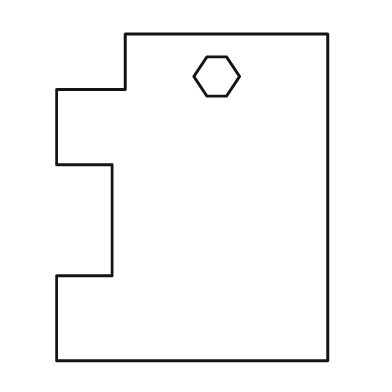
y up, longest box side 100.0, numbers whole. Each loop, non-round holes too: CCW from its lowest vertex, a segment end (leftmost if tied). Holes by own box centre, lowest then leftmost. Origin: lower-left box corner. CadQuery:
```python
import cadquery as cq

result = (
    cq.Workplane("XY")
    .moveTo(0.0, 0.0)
    .lineTo(83.0, 0.0)
    .lineTo(83.0, 100.0)
    .lineTo(21.0, 100.0)
    .lineTo(21.0, 83.0)
    .lineTo(0.0, 83.0)
    .lineTo(0.0, 60.0)
    .lineTo(17.0, 60.0)
    .lineTo(17.0, 26.0)
    .lineTo(0.0, 26.0)
    .close()
    .moveTo(46.0, 81.0)
    .lineTo(52.0, 81.0)
    .lineTo(56.0, 87.0)
    .lineTo(52.0, 93.0)
    .lineTo(46.0, 93.0)
    .lineTo(42.0, 87.0)
    .close()
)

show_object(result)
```